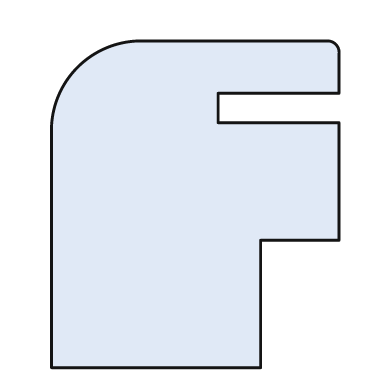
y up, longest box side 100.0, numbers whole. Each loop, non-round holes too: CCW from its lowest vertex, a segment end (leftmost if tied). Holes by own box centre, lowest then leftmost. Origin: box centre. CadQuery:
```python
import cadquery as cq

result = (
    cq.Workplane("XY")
    .moveTo(-44.0, -50.0)
    .lineTo(20.0, -50.0)
    .lineTo(20.0, -11.0)
    .lineTo(44.0, -11.0)
    .lineTo(44.0, 25.0)
    .lineTo(7.0, 25.0)
    .lineTo(7.0, 34.0)
    .lineTo(44.0, 34.0)
    .lineTo(44.0, 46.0)
    .threePointArc((43.0, 49.0), (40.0, 50.0))
    .lineTo(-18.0, 50.0)
    .threePointArc((-36.0, 42.0), (-44.0, 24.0))
    .close()
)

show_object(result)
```